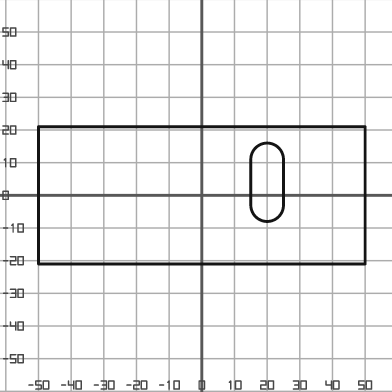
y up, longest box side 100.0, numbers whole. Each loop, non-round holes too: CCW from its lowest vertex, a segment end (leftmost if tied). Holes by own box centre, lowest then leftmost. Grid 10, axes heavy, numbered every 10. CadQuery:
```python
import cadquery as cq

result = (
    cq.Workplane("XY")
    .moveTo(-50.0, -21.0)
    .lineTo(50.0, -21.0)
    .lineTo(50.0, 21.0)
    .lineTo(-50.0, 21.0)
    .close()
    .moveTo(15.0, -3.0)
    .threePointArc((20.0, -8.0), (25.0, -3.0))
    .lineTo(25.0, 11.0)
    .threePointArc((20.0, 16.0), (15.0, 11.0))
    .close()
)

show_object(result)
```